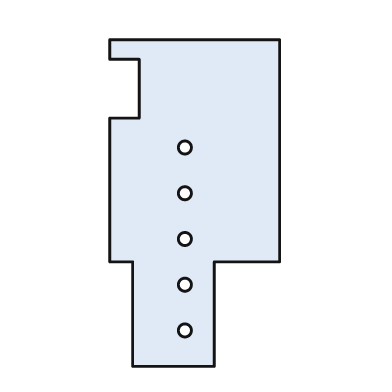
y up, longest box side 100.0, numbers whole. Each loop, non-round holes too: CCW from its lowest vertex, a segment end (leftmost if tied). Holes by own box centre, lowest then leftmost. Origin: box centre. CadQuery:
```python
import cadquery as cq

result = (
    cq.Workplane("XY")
    .moveTo(-19.0, -50.0)
    .lineTo(6.0, -50.0)
    .lineTo(6.0, -18.0)
    .lineTo(26.0, -18.0)
    .lineTo(26.0, 50.0)
    .lineTo(-26.0, 50.0)
    .lineTo(-26.0, 44.0)
    .lineTo(-17.0, 44.0)
    .lineTo(-17.0, 26.0)
    .lineTo(-26.0, 26.0)
    .lineTo(-26.0, -18.0)
    .lineTo(-19.0, -18.0)
    .close()
    .moveTo(-3.0, -39.0)
    .circle(2.0)
    .moveTo(-3.0, -25.0)
    .circle(2.0)
    .moveTo(-3.0, -11.0)
    .circle(2.0)
    .moveTo(-3.0, 3.0)
    .circle(2.0)
    .moveTo(-3.0, 17.0)
    .circle(2.0)
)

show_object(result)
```